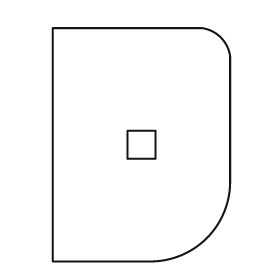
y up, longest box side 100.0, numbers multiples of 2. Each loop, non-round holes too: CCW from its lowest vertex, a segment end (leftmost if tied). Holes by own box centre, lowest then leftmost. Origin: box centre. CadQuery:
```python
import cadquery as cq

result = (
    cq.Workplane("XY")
    .moveTo(-38.0, -50.0)
    .lineTo(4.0, -50.0)
    .threePointArc((28.0, -40.0), (38.0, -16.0))
    .lineTo(38.0, 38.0)
    .threePointArc((34.0, 46.0), (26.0, 50.0))
    .lineTo(-38.0, 50.0)
    .close()
    .moveTo(-6.0, -6.0)
    .lineTo(6.0, -6.0)
    .lineTo(6.0, 6.0)
    .lineTo(-6.0, 6.0)
    .close()
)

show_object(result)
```